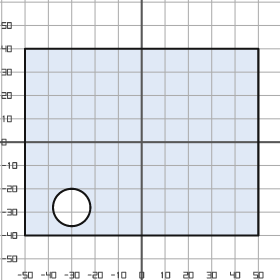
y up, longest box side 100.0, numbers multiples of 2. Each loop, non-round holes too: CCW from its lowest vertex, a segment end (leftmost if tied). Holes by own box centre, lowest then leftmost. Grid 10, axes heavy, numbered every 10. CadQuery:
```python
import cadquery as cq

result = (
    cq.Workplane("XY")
    .moveTo(-50.0, -40.0)
    .lineTo(50.0, -40.0)
    .lineTo(50.0, 40.0)
    .lineTo(-50.0, 40.0)
    .close()
    .moveTo(-30.0, -28.0)
    .circle(8.0)
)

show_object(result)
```